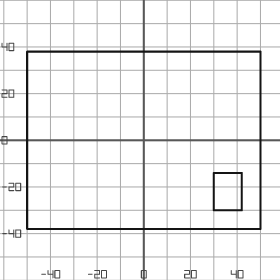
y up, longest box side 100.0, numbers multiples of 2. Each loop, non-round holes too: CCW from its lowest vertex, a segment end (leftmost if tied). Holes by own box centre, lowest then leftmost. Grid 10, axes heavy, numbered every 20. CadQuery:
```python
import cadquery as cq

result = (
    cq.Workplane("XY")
    .moveTo(-50.0, -38.0)
    .lineTo(50.0, -38.0)
    .lineTo(50.0, 38.0)
    .lineTo(-50.0, 38.0)
    .close()
    .moveTo(30.0, -30.0)
    .lineTo(42.0, -30.0)
    .lineTo(42.0, -14.0)
    .lineTo(30.0, -14.0)
    .close()
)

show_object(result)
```